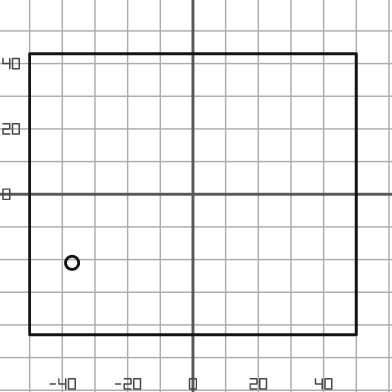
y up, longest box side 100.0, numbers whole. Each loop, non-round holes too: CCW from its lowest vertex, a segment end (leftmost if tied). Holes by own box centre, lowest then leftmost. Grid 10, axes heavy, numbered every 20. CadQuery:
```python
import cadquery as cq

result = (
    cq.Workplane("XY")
    .moveTo(-50.0, -43.0)
    .lineTo(50.0, -43.0)
    .lineTo(50.0, 43.0)
    .lineTo(-50.0, 43.0)
    .close()
    .moveTo(-37.0, -21.0)
    .circle(2.0)
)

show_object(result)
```